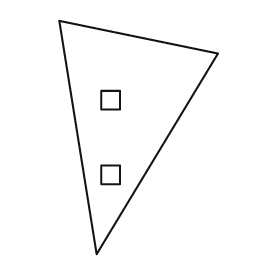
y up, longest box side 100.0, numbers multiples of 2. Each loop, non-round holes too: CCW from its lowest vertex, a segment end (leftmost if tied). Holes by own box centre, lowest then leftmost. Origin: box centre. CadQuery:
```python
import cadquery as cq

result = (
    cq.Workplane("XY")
    .moveTo(-18.0, -50.0)
    .lineTo(34.0, 36.0)
    .lineTo(-34.0, 50.0)
    .close()
    .moveTo(-16.0, -20.0)
    .lineTo(-8.0, -20.0)
    .lineTo(-8.0, -12.0)
    .lineTo(-16.0, -12.0)
    .close()
    .moveTo(-16.0, 12.0)
    .lineTo(-8.0, 12.0)
    .lineTo(-8.0, 20.0)
    .lineTo(-16.0, 20.0)
    .close()
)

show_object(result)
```